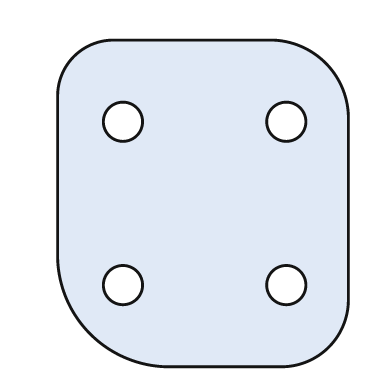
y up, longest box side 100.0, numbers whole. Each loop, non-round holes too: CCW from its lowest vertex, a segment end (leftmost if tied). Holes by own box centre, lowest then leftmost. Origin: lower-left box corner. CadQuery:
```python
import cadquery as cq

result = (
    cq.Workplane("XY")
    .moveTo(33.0, 0.0)
    .lineTo(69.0, 0.0)
    .threePointArc((83.0, 6.0), (89.0, 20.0))
    .lineTo(89.0, 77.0)
    .threePointArc((82.0, 93.0), (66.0, 100.0))
    .lineTo(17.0, 100.0)
    .threePointArc((5.0, 95.0), (0.0, 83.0))
    .lineTo(0.0, 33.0)
    .threePointArc((10.0, 10.0), (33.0, 0.0))
    .close()
    .moveTo(20.0, 25.0)
    .circle(6.0)
    .moveTo(70.0, 25.0)
    .circle(6.0)
    .moveTo(20.0, 75.0)
    .circle(6.0)
    .moveTo(70.0, 75.0)
    .circle(6.0)
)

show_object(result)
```